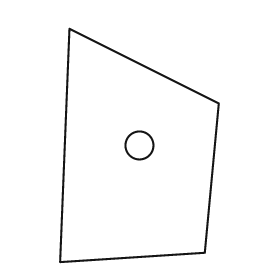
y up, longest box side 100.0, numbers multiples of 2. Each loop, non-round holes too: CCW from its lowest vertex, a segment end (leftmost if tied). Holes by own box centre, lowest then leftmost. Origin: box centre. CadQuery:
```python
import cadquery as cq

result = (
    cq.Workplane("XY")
    .moveTo(-34.0, -50.0)
    .lineTo(28.0, -46.0)
    .lineTo(34.0, 18.0)
    .lineTo(-30.0, 50.0)
    .close()
    .moveTo(0.0, 0.0)
    .circle(6.0)
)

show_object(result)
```